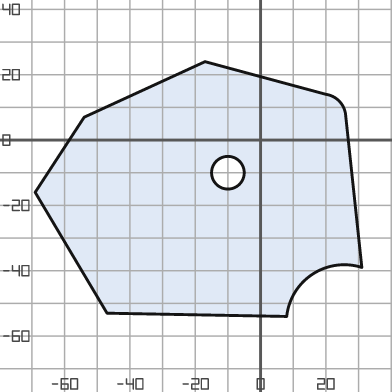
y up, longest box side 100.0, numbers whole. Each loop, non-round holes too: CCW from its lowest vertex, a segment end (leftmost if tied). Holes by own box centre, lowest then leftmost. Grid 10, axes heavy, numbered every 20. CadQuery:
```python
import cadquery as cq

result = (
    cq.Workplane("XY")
    .moveTo(8.0, -54.0)
    .threePointArc((16.0, -41.0), (31.0, -39.0))
    .lineTo(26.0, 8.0)
    .threePointArc((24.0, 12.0), (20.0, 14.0))
    .lineTo(-17.0, 24.0)
    .lineTo(-54.0, 7.0)
    .lineTo(-69.0, -16.0)
    .lineTo(-47.0, -53.0)
    .close()
    .moveTo(-10.0, -10.0)
    .circle(5.0)
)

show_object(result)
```